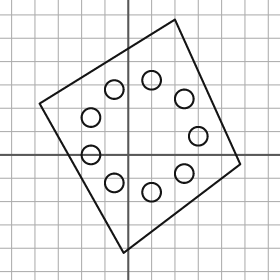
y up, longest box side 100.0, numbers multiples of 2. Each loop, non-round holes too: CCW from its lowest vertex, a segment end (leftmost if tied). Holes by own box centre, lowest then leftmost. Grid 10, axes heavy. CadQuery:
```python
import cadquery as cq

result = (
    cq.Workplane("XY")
    .moveTo(-2.0, -42.0)
    .lineTo(48.0, -4.0)
    .lineTo(20.0, 58.0)
    .lineTo(-38.0, 22.0)
    .close()
    .moveTo(10.0, -16.0)
    .circle(4.0)
    .moveTo(-6.0, -12.0)
    .circle(4.0)
    .moveTo(24.0, -8.0)
    .circle(4.0)
    .moveTo(-16.0, 0.0)
    .circle(4.0)
    .moveTo(30.0, 8.0)
    .circle(4.0)
    .moveTo(-16.0, 16.0)
    .circle(4.0)
    .moveTo(24.0, 24.0)
    .circle(4.0)
    .moveTo(-6.0, 28.0)
    .circle(4.0)
    .moveTo(10.0, 32.0)
    .circle(4.0)
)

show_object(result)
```